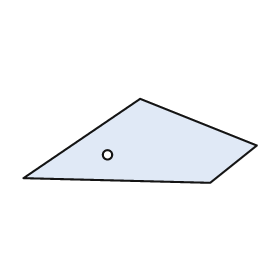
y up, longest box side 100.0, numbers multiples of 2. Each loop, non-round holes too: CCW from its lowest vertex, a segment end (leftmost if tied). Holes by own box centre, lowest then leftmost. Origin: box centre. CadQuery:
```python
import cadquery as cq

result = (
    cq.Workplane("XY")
    .moveTo(30.0, -18.0)
    .lineTo(50.0, -2.0)
    .lineTo(0.0, 18.0)
    .lineTo(-50.0, -16.0)
    .close()
    .moveTo(-14.0, -6.0)
    .circle(2.0)
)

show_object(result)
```